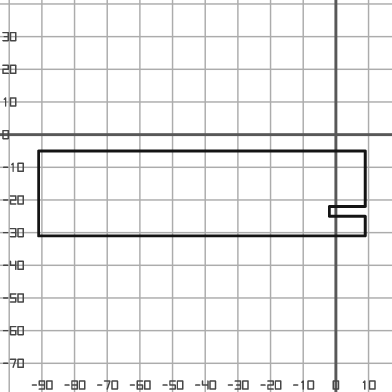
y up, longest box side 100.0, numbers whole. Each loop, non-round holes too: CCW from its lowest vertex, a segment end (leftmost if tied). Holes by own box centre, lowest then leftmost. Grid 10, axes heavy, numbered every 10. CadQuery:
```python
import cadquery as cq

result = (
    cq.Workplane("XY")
    .moveTo(-91.0, -31.0)
    .lineTo(9.0, -31.0)
    .lineTo(9.0, -25.0)
    .lineTo(-2.0, -25.0)
    .lineTo(-2.0, -22.0)
    .lineTo(9.0, -22.0)
    .lineTo(9.0, -5.0)
    .lineTo(-91.0, -5.0)
    .close()
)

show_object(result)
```